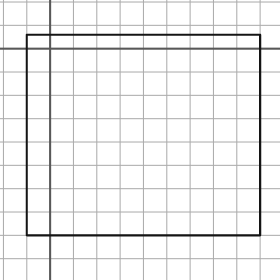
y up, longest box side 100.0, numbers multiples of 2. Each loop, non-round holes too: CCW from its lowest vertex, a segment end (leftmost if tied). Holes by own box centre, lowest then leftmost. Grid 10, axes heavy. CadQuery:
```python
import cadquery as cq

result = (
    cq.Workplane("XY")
    .moveTo(-10.0, -80.0)
    .lineTo(90.0, -80.0)
    .lineTo(90.0, 6.0)
    .lineTo(-10.0, 6.0)
    .close()
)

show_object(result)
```